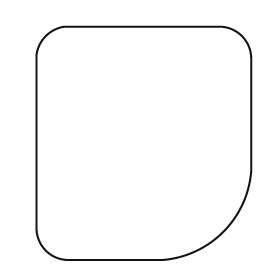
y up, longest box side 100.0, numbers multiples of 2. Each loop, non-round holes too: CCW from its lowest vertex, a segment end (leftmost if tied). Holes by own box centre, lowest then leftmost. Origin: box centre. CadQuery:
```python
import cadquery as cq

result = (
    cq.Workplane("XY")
    .moveTo(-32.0, -50.0)
    .lineTo(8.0, -50.0)
    .threePointArc((34.0, -38.0), (46.0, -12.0))
    .lineTo(46.0, 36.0)
    .threePointArc((42.0, 46.0), (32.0, 50.0))
    .lineTo(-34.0, 50.0)
    .threePointArc((-42.0, 46.0), (-46.0, 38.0))
    .lineTo(-46.0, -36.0)
    .threePointArc((-42.0, -46.0), (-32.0, -50.0))
    .close()
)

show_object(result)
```